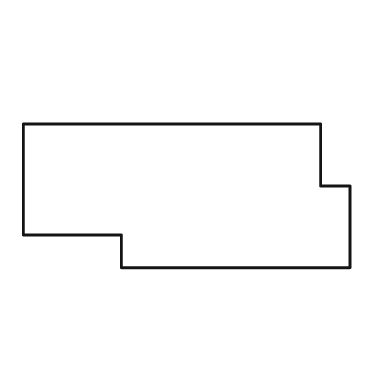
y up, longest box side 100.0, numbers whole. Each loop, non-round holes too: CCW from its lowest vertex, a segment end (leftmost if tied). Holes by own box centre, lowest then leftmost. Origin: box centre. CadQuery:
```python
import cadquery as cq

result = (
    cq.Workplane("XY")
    .moveTo(-20.0, -22.0)
    .lineTo(50.0, -22.0)
    .lineTo(50.0, 3.0)
    .lineTo(41.0, 3.0)
    .lineTo(41.0, 22.0)
    .lineTo(-50.0, 22.0)
    .lineTo(-50.0, -12.0)
    .lineTo(-20.0, -12.0)
    .close()
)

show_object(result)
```